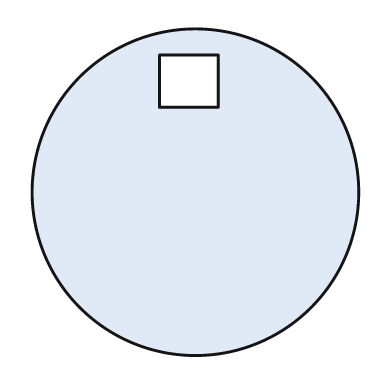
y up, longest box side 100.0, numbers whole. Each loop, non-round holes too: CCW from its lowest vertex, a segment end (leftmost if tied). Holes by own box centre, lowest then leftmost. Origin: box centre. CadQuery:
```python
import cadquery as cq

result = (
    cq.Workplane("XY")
    .moveTo(0.0, 0.0)
    .circle(50.0)
    .moveTo(-11.0, 26.0)
    .lineTo(7.0, 26.0)
    .lineTo(7.0, 42.0)
    .lineTo(-11.0, 42.0)
    .close()
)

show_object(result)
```